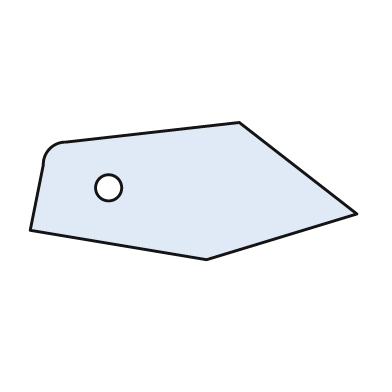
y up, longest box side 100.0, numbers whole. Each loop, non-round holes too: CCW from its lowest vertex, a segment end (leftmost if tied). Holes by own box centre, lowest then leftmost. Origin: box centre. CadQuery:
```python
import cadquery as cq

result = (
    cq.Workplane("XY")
    .moveTo(4.0, -21.0)
    .lineTo(50.0, -7.0)
    .lineTo(14.0, 21.0)
    .lineTo(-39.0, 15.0)
    .threePointArc((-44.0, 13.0), (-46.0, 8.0))
    .lineTo(-50.0, -12.0)
    .close()
    .moveTo(-26.0, 1.0)
    .circle(4.0)
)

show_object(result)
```